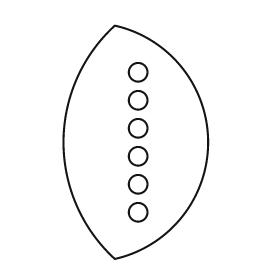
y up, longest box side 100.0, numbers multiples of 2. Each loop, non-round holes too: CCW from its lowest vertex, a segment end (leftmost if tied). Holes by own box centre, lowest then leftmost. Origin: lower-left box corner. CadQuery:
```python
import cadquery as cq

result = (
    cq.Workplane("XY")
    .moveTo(22.0, 0.0)
    .threePointArc((62.0, 50.0), (22.0, 100.0))
    .threePointArc((0.0, 50.0), (22.0, 0.0))
    .close()
    .moveTo(32.0, 20.0)
    .circle(4.0)
    .moveTo(32.0, 32.0)
    .circle(4.0)
    .moveTo(32.0, 44.0)
    .circle(4.0)
    .moveTo(32.0, 56.0)
    .circle(4.0)
    .moveTo(32.0, 68.0)
    .circle(4.0)
    .moveTo(32.0, 80.0)
    .circle(4.0)
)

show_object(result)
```